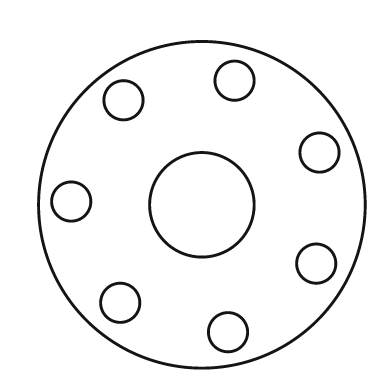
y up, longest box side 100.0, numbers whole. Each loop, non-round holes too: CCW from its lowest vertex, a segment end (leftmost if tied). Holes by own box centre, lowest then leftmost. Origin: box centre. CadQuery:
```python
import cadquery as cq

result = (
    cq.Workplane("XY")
    .moveTo(0.0, 0.0)
    .circle(50.0)
    .moveTo(8.0, -39.0)
    .circle(6.0)
    .moveTo(-25.0, -30.0)
    .circle(6.0)
    .moveTo(35.0, -18.0)
    .circle(6.0)
    .moveTo(0.0, 0.0)
    .circle(16.0)
    .moveTo(-40.0, 1.0)
    .circle(6.0)
    .moveTo(36.0, 16.0)
    .circle(6.0)
    .moveTo(-24.0, 32.0)
    .circle(6.0)
    .moveTo(10.0, 38.0)
    .circle(6.0)
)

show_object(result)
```